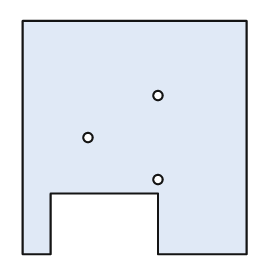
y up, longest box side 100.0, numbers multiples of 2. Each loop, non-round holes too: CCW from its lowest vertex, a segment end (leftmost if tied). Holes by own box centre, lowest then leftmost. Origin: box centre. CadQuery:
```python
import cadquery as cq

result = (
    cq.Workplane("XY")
    .moveTo(-48.0, -50.0)
    .lineTo(-36.0, -50.0)
    .lineTo(-36.0, -24.0)
    .lineTo(10.0, -24.0)
    .lineTo(10.0, -50.0)
    .lineTo(48.0, -50.0)
    .lineTo(48.0, 50.0)
    .lineTo(-48.0, 50.0)
    .close()
    .moveTo(10.0, -18.0)
    .circle(2.0)
    .moveTo(-20.0, 0.0)
    .circle(2.0)
    .moveTo(10.0, 18.0)
    .circle(2.0)
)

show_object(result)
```